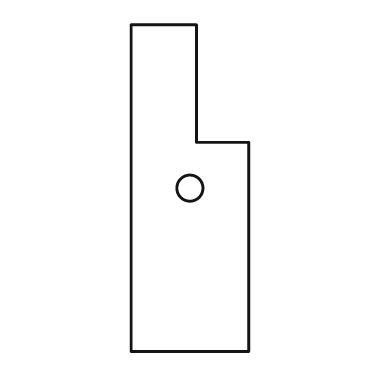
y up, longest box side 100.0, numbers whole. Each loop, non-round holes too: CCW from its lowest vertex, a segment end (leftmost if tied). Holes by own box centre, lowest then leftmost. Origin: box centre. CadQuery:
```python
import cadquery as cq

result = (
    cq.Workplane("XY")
    .moveTo(-18.0, -50.0)
    .lineTo(18.0, -50.0)
    .lineTo(18.0, 14.0)
    .lineTo(2.0, 14.0)
    .lineTo(2.0, 50.0)
    .lineTo(-18.0, 50.0)
    .close()
    .moveTo(0.0, 0.0)
    .circle(4.0)
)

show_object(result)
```